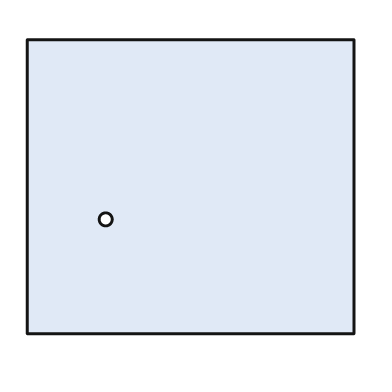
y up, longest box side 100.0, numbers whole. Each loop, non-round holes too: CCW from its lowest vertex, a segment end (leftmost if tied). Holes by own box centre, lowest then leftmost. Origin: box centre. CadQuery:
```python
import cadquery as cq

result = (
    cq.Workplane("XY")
    .moveTo(-50.0, -45.0)
    .lineTo(50.0, -45.0)
    .lineTo(50.0, 45.0)
    .lineTo(-50.0, 45.0)
    .close()
    .moveTo(-26.0, -10.0)
    .circle(2.0)
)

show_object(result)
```